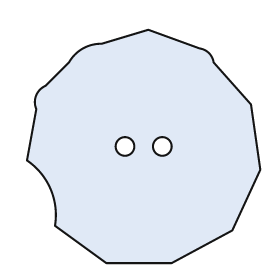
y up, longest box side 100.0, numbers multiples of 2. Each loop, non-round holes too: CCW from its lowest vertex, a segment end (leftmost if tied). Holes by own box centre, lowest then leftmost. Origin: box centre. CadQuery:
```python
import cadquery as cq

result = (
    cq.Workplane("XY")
    .moveTo(-16.0, -50.0)
    .lineTo(12.0, -50.0)
    .lineTo(38.0, -36.0)
    .lineTo(50.0, -10.0)
    .lineTo(46.0, 18.0)
    .lineTo(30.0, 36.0)
    .threePointArc((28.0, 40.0), (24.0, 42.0))
    .lineTo(2.0, 50.0)
    .lineTo(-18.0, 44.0)
    .threePointArc((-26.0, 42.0), (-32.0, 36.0))
    .lineTo(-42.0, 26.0)
    .threePointArc((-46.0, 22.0), (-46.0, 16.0))
    .lineTo(-50.0, -6.0)
    .threePointArc((-40.0, -18.0), (-38.0, -34.0))
    .close()
    .moveTo(-8.0, 0.0)
    .circle(4.0)
    .moveTo(8.0, 0.0)
    .circle(4.0)
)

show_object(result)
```